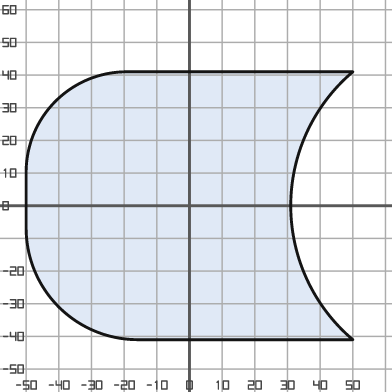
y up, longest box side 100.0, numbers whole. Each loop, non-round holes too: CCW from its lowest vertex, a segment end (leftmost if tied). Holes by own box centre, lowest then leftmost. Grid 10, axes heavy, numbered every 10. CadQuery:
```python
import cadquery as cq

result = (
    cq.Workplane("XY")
    .moveTo(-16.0, -41.0)
    .lineTo(50.0, -41.0)
    .threePointArc((31.0, 0.0), (50.0, 41.0))
    .lineTo(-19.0, 41.0)
    .threePointArc((-41.0, 32.0), (-50.0, 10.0))
    .lineTo(-50.0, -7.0)
    .threePointArc((-40.0, -31.0), (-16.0, -41.0))
    .close()
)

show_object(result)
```